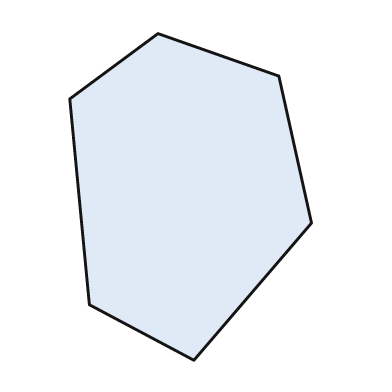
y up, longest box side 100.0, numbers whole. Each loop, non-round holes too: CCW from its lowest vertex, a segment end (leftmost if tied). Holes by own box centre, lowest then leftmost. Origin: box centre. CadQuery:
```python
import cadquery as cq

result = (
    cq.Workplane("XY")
    .moveTo(1.0, -50.0)
    .lineTo(37.0, -8.0)
    .lineTo(27.0, 37.0)
    .lineTo(-10.0, 50.0)
    .lineTo(-37.0, 30.0)
    .lineTo(-31.0, -33.0)
    .close()
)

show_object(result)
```